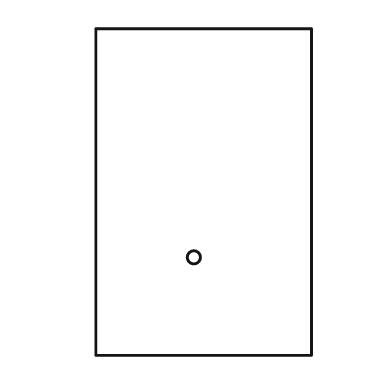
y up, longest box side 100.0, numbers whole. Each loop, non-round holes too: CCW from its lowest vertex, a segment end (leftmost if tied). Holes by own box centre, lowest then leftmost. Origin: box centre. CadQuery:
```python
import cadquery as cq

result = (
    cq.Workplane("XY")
    .moveTo(-33.0, -50.0)
    .lineTo(33.0, -50.0)
    .lineTo(33.0, 50.0)
    .lineTo(-33.0, 50.0)
    .close()
    .moveTo(-3.0, -20.0)
    .circle(2.0)
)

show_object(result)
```